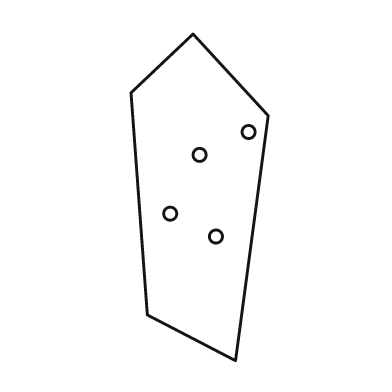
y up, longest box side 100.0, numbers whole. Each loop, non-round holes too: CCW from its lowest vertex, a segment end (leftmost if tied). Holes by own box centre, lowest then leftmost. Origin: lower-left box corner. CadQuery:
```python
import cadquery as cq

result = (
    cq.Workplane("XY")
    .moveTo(32.0, 0.0)
    .lineTo(42.0, 75.0)
    .lineTo(19.0, 100.0)
    .lineTo(0.0, 82.0)
    .lineTo(5.0, 14.0)
    .close()
    .moveTo(26.0, 38.0)
    .circle(2.0)
    .moveTo(12.0, 45.0)
    .circle(2.0)
    .moveTo(21.0, 63.0)
    .circle(2.0)
    .moveTo(36.0, 70.0)
    .circle(2.0)
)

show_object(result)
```